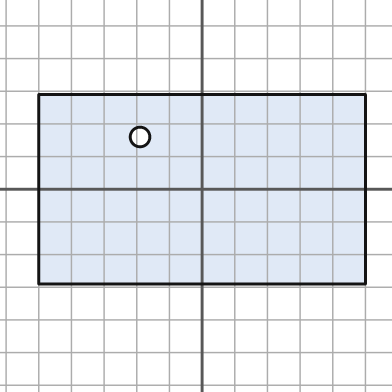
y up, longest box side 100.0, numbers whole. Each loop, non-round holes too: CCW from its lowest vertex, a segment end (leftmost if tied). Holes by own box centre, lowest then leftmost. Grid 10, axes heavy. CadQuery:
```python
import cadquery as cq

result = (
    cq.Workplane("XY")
    .moveTo(-50.0, -29.0)
    .lineTo(50.0, -29.0)
    .lineTo(50.0, 29.0)
    .lineTo(-50.0, 29.0)
    .close()
    .moveTo(-19.0, 16.0)
    .circle(3.0)
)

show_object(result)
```